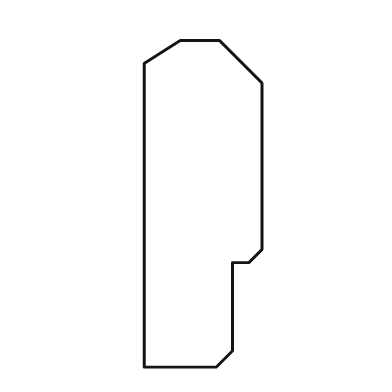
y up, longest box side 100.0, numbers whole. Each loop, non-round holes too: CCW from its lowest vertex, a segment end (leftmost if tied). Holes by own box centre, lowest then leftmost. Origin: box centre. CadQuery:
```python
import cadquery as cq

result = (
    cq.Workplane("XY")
    .moveTo(-18.0, -50.0)
    .lineTo(4.0, -50.0)
    .lineTo(9.0, -45.0)
    .lineTo(9.0, -18.0)
    .lineTo(14.0, -18.0)
    .lineTo(18.0, -14.0)
    .lineTo(18.0, 37.0)
    .lineTo(5.0, 50.0)
    .lineTo(-7.0, 50.0)
    .lineTo(-18.0, 43.0)
    .close()
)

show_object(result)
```